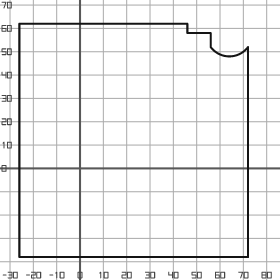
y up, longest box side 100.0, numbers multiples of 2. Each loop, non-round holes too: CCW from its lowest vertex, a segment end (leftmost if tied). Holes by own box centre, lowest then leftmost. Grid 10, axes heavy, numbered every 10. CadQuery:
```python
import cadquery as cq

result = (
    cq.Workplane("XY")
    .moveTo(-26.0, -38.0)
    .lineTo(72.0, -38.0)
    .lineTo(72.0, 52.0)
    .threePointArc((64.0, 48.0), (56.0, 52.0))
    .lineTo(56.0, 58.0)
    .lineTo(46.0, 58.0)
    .lineTo(46.0, 62.0)
    .lineTo(-26.0, 62.0)
    .close()
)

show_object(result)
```